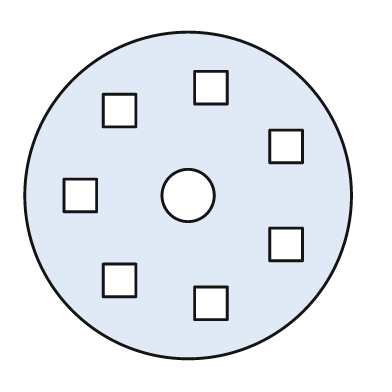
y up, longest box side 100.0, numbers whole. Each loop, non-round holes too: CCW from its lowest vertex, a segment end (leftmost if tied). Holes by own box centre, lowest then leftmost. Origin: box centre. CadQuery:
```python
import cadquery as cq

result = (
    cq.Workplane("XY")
    .moveTo(0.0, 0.0)
    .circle(50.0)
    .moveTo(2.0, -38.0)
    .lineTo(12.0, -38.0)
    .lineTo(12.0, -28.0)
    .lineTo(2.0, -28.0)
    .close()
    .moveTo(-26.0, -31.0)
    .lineTo(-16.0, -31.0)
    .lineTo(-16.0, -21.0)
    .lineTo(-26.0, -21.0)
    .close()
    .moveTo(25.0, -20.0)
    .lineTo(35.0, -20.0)
    .lineTo(35.0, -10.0)
    .lineTo(25.0, -10.0)
    .close()
    .moveTo(-38.0, -5.0)
    .lineTo(-28.0, -5.0)
    .lineTo(-28.0, 5.0)
    .lineTo(-38.0, 5.0)
    .close()
    .moveTo(0.0, 0.0)
    .circle(8.0)
    .moveTo(25.0, 10.0)
    .lineTo(35.0, 10.0)
    .lineTo(35.0, 20.0)
    .lineTo(25.0, 20.0)
    .close()
    .moveTo(-26.0, 21.0)
    .lineTo(-16.0, 21.0)
    .lineTo(-16.0, 31.0)
    .lineTo(-26.0, 31.0)
    .close()
    .moveTo(2.0, 28.0)
    .lineTo(12.0, 28.0)
    .lineTo(12.0, 38.0)
    .lineTo(2.0, 38.0)
    .close()
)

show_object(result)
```